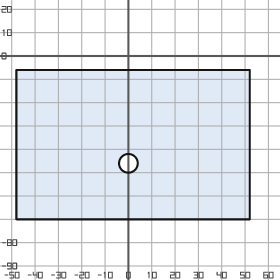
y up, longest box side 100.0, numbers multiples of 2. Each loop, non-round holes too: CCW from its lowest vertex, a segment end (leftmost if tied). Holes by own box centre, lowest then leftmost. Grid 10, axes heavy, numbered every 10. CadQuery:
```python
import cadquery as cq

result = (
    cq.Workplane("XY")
    .moveTo(-48.0, -70.0)
    .lineTo(52.0, -70.0)
    .lineTo(52.0, -6.0)
    .lineTo(-48.0, -6.0)
    .close()
    .moveTo(0.0, -46.0)
    .circle(4.0)
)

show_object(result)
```